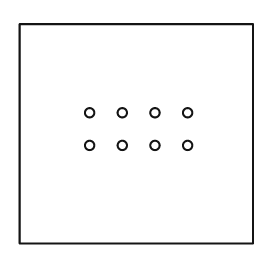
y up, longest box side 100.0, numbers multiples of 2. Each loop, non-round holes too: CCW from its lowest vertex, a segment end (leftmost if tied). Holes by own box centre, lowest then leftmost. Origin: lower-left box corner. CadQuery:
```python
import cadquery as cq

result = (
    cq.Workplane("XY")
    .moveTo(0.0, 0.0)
    .lineTo(100.0, 0.0)
    .lineTo(100.0, 94.0)
    .lineTo(0.0, 94.0)
    .close()
    .moveTo(30.0, 42.0)
    .circle(2.0)
    .moveTo(44.0, 42.0)
    .circle(2.0)
    .moveTo(58.0, 42.0)
    .circle(2.0)
    .moveTo(72.0, 42.0)
    .circle(2.0)
    .moveTo(30.0, 56.0)
    .circle(2.0)
    .moveTo(44.0, 56.0)
    .circle(2.0)
    .moveTo(58.0, 56.0)
    .circle(2.0)
    .moveTo(72.0, 56.0)
    .circle(2.0)
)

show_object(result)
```